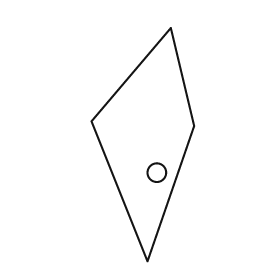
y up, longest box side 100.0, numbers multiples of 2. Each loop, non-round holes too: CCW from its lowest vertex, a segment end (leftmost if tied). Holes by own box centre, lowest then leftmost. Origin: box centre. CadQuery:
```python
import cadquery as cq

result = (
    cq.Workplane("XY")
    .moveTo(2.0, -50.0)
    .lineTo(22.0, 8.0)
    .lineTo(12.0, 50.0)
    .lineTo(-22.0, 10.0)
    .close()
    .moveTo(6.0, -12.0)
    .circle(4.0)
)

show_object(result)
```